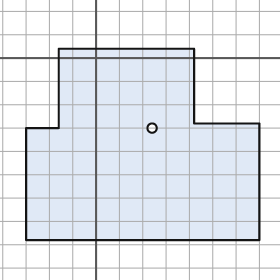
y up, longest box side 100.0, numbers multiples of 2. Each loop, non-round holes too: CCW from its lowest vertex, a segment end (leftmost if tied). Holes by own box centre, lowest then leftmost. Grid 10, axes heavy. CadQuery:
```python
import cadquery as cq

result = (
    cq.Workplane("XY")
    .moveTo(-30.0, -78.0)
    .lineTo(70.0, -78.0)
    .lineTo(70.0, -28.0)
    .lineTo(42.0, -28.0)
    .lineTo(42.0, 4.0)
    .lineTo(-16.0, 4.0)
    .lineTo(-16.0, -30.0)
    .lineTo(-30.0, -30.0)
    .close()
    .moveTo(24.0, -30.0)
    .circle(2.0)
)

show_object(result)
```